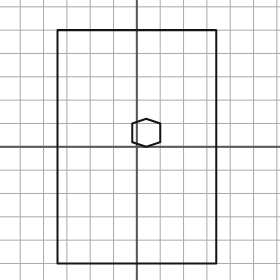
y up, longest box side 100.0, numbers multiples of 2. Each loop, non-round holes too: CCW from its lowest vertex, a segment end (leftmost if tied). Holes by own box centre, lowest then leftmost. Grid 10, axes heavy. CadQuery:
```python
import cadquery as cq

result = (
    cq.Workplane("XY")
    .moveTo(-34.0, -50.0)
    .lineTo(34.0, -50.0)
    .lineTo(34.0, 50.0)
    .lineTo(-34.0, 50.0)
    .close()
    .moveTo(4.0, 0.0)
    .lineTo(10.0, 2.0)
    .lineTo(10.0, 10.0)
    .lineTo(4.0, 12.0)
    .lineTo(-2.0, 10.0)
    .lineTo(-2.0, 2.0)
    .close()
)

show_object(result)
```